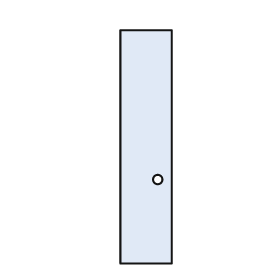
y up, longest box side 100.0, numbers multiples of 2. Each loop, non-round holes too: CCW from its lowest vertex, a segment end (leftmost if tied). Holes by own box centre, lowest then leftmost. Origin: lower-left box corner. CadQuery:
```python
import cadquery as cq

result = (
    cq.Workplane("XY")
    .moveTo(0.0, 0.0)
    .lineTo(22.0, 0.0)
    .lineTo(22.0, 100.0)
    .lineTo(0.0, 100.0)
    .close()
    .moveTo(16.0, 36.0)
    .circle(2.0)
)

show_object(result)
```